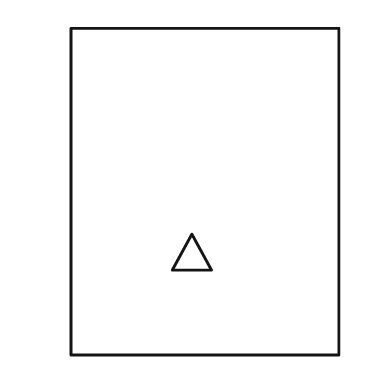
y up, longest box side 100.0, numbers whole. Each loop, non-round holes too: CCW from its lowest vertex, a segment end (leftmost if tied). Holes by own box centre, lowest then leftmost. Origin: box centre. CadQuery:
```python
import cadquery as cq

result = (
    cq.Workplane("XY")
    .moveTo(-41.0, -50.0)
    .lineTo(41.0, -50.0)
    .lineTo(41.0, 50.0)
    .lineTo(-41.0, 50.0)
    .close()
    .moveTo(-10.0, -24.0)
    .lineTo(2.0, -24.0)
    .lineTo(-4.0, -13.0)
    .close()
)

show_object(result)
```